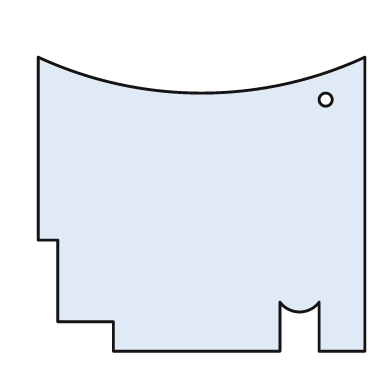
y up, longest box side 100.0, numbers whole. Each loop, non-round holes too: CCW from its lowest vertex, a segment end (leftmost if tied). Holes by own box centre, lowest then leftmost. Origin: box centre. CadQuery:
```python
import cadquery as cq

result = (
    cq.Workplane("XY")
    .moveTo(-27.0, -45.0)
    .lineTo(24.0, -45.0)
    .lineTo(24.0, -30.0)
    .threePointArc((30.0, -33.0), (36.0, -30.0))
    .lineTo(36.0, -45.0)
    .lineTo(50.0, -45.0)
    .lineTo(50.0, 45.0)
    .threePointArc((0.0, 34.0), (-50.0, 45.0))
    .lineTo(-50.0, -11.0)
    .lineTo(-44.0, -11.0)
    .lineTo(-44.0, -36.0)
    .lineTo(-27.0, -36.0)
    .close()
    .moveTo(38.0, 32.0)
    .circle(2.0)
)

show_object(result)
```